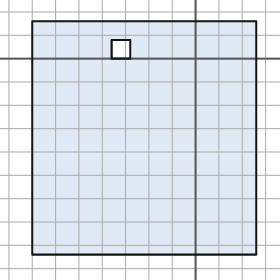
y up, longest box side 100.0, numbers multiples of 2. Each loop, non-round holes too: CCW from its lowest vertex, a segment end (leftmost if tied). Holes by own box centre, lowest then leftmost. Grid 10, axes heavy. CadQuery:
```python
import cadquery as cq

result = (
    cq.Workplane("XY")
    .moveTo(-70.0, -84.0)
    .lineTo(26.0, -84.0)
    .lineTo(26.0, 16.0)
    .lineTo(-70.0, 16.0)
    .close()
    .moveTo(-36.0, 0.0)
    .lineTo(-28.0, 0.0)
    .lineTo(-28.0, 8.0)
    .lineTo(-36.0, 8.0)
    .close()
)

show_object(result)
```